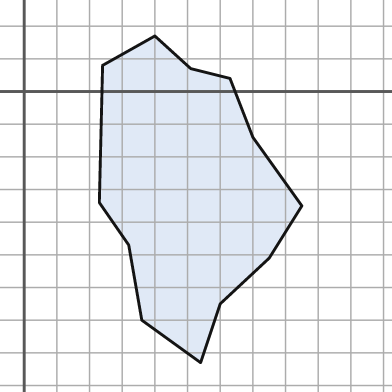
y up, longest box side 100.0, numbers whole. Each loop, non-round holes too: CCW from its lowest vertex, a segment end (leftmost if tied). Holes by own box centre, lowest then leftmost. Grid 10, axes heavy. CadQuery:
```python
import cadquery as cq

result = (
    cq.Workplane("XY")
    .moveTo(54.0, -83.0)
    .lineTo(60.0, -65.0)
    .lineTo(75.0, -51.0)
    .lineTo(85.0, -35.0)
    .lineTo(70.0, -14.0)
    .lineTo(63.0, 4.0)
    .lineTo(51.0, 7.0)
    .lineTo(40.0, 17.0)
    .lineTo(24.0, 8.0)
    .lineTo(23.0, -34.0)
    .lineTo(32.0, -47.0)
    .lineTo(36.0, -70.0)
    .close()
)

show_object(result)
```